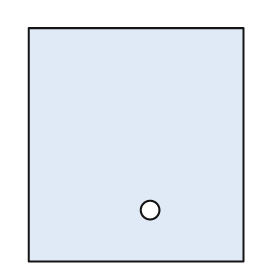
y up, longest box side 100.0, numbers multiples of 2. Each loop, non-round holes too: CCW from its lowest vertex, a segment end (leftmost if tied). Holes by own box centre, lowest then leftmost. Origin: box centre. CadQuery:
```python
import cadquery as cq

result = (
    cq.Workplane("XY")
    .moveTo(-46.0, -50.0)
    .lineTo(46.0, -50.0)
    .lineTo(46.0, 50.0)
    .lineTo(-46.0, 50.0)
    .close()
    .moveTo(6.0, -28.0)
    .circle(4.0)
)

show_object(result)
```